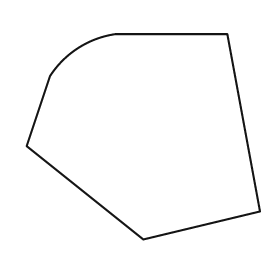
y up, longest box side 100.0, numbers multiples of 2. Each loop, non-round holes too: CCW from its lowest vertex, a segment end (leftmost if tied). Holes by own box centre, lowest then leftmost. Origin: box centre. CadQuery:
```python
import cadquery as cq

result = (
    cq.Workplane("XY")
    .moveTo(0.0, -44.0)
    .lineTo(50.0, -32.0)
    .lineTo(36.0, 44.0)
    .lineTo(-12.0, 44.0)
    .threePointArc((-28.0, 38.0), (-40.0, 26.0))
    .lineTo(-50.0, -4.0)
    .close()
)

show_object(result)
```